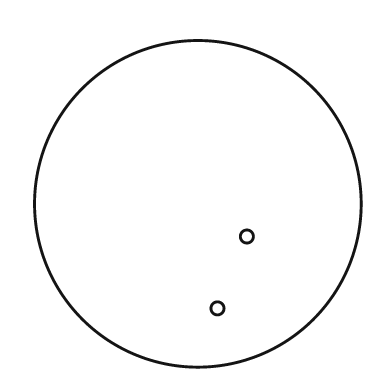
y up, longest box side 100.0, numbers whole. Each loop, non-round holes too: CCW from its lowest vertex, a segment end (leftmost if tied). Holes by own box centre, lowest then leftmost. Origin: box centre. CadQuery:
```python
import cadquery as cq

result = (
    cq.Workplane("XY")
    .moveTo(0.0, 0.0)
    .circle(50.0)
    .moveTo(6.0, -32.0)
    .circle(2.0)
    .moveTo(15.0, -10.0)
    .circle(2.0)
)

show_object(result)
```